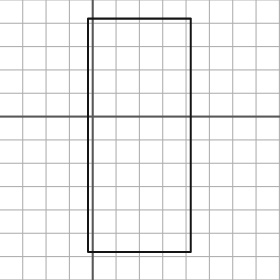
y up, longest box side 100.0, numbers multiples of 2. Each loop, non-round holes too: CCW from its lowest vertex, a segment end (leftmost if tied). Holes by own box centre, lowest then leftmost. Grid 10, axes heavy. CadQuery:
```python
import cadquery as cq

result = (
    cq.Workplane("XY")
    .moveTo(-2.0, -58.0)
    .lineTo(42.0, -58.0)
    .lineTo(42.0, 42.0)
    .lineTo(-2.0, 42.0)
    .close()
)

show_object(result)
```